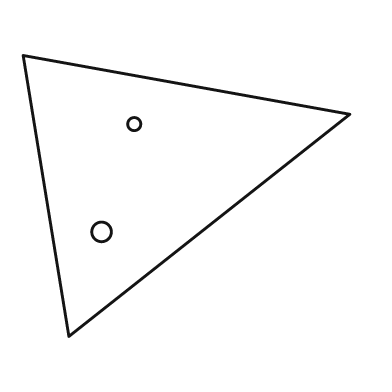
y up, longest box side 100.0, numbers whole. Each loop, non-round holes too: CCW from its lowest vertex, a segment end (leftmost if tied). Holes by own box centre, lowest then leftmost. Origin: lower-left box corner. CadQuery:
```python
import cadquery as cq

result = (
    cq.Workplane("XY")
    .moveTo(14.0, 0.0)
    .lineTo(100.0, 68.0)
    .lineTo(0.0, 86.0)
    .close()
    .moveTo(24.0, 32.0)
    .circle(3.0)
    .moveTo(34.0, 65.0)
    .circle(2.0)
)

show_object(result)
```